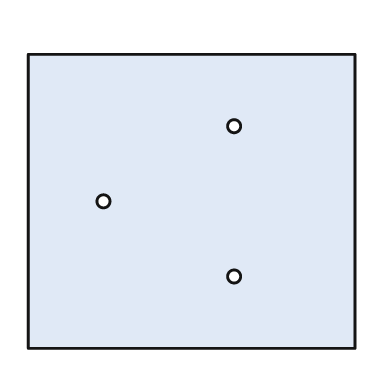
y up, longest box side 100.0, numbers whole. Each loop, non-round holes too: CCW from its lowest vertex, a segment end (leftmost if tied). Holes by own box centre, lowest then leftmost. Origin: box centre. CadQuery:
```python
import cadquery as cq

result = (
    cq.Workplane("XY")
    .moveTo(-50.0, -45.0)
    .lineTo(50.0, -45.0)
    .lineTo(50.0, 45.0)
    .lineTo(-50.0, 45.0)
    .close()
    .moveTo(13.0, -23.0)
    .circle(2.0)
    .moveTo(-27.0, 0.0)
    .circle(2.0)
    .moveTo(13.0, 23.0)
    .circle(2.0)
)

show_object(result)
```